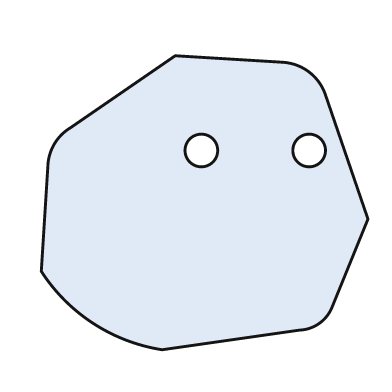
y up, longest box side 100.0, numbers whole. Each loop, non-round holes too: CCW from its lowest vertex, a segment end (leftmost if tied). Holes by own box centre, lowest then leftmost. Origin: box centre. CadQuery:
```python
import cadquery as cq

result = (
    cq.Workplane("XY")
    .moveTo(-13.0, -45.0)
    .lineTo(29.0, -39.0)
    .threePointArc((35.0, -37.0), (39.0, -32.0))
    .lineTo(50.0, -5.0)
    .lineTo(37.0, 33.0)
    .threePointArc((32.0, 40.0), (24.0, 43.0))
    .lineTo(-9.0, 45.0)
    .lineTo(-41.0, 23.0)
    .threePointArc((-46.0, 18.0), (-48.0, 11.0))
    .lineTo(-50.0, -21.0)
    .threePointArc((-34.0, -37.0), (-13.0, -45.0))
    .close()
    .moveTo(-1.0, 16.0)
    .circle(5.0)
    .moveTo(32.0, 16.0)
    .circle(5.0)
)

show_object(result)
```